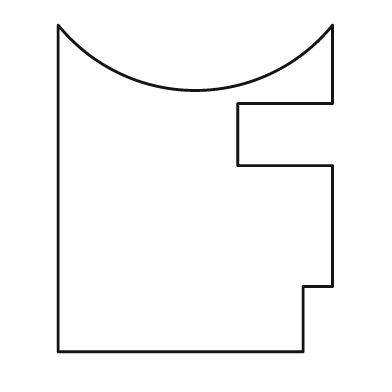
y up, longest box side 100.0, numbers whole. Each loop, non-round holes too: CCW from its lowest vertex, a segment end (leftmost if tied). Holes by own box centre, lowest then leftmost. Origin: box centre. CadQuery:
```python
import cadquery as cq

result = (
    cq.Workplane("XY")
    .moveTo(-42.0, -50.0)
    .lineTo(33.0, -50.0)
    .lineTo(33.0, -30.0)
    .lineTo(42.0, -30.0)
    .lineTo(42.0, 7.0)
    .lineTo(13.0, 7.0)
    .lineTo(13.0, 26.0)
    .lineTo(42.0, 26.0)
    .lineTo(42.0, 50.0)
    .threePointArc((0.0, 30.0), (-42.0, 50.0))
    .close()
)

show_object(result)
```